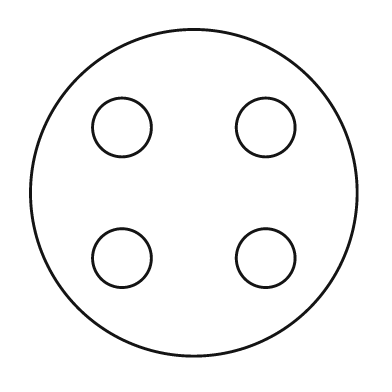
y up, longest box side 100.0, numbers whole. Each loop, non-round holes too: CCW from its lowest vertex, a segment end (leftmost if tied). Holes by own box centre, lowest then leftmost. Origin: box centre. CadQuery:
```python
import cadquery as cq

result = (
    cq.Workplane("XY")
    .moveTo(0.0, 0.0)
    .circle(50.0)
    .moveTo(-22.0, -20.0)
    .circle(9.0)
    .moveTo(22.0, -20.0)
    .circle(9.0)
    .moveTo(-22.0, 20.0)
    .circle(9.0)
    .moveTo(22.0, 20.0)
    .circle(9.0)
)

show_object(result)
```